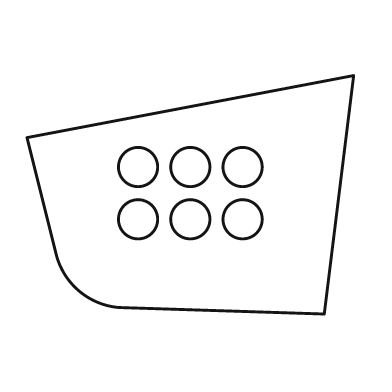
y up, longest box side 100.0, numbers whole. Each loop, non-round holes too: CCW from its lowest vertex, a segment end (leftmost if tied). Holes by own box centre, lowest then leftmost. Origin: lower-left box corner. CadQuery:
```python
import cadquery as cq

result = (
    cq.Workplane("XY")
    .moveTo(91.0, 0.0)
    .lineTo(100.0, 73.0)
    .lineTo(0.0, 54.0)
    .lineTo(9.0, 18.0)
    .threePointArc((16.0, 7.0), (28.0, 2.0))
    .close()
    .moveTo(34.0, 29.0)
    .circle(6.0)
    .moveTo(50.0, 29.0)
    .circle(6.0)
    .moveTo(66.0, 29.0)
    .circle(6.0)
    .moveTo(34.0, 45.0)
    .circle(6.0)
    .moveTo(50.0, 45.0)
    .circle(6.0)
    .moveTo(66.0, 45.0)
    .circle(6.0)
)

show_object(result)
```